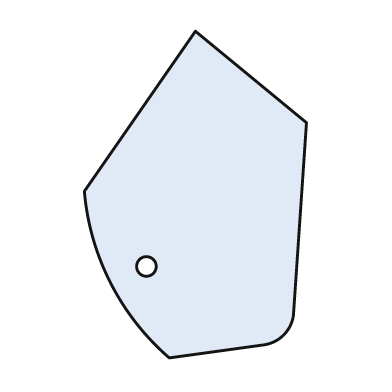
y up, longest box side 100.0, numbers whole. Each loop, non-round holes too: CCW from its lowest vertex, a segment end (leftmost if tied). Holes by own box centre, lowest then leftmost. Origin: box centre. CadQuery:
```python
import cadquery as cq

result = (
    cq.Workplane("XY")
    .moveTo(-8.0, -50.0)
    .lineTo(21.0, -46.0)
    .threePointArc((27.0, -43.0), (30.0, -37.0))
    .lineTo(34.0, 22.0)
    .lineTo(0.0, 50.0)
    .lineTo(-34.0, 1.0)
    .threePointArc((-26.0, -27.0), (-8.0, -50.0))
    .close()
    .moveTo(-15.0, -22.0)
    .circle(3.0)
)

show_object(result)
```